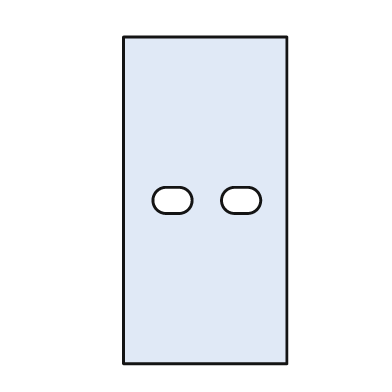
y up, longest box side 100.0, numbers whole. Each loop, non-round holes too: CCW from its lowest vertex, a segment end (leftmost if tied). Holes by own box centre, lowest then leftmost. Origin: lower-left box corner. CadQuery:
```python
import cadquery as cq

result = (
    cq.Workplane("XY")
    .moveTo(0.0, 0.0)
    .lineTo(50.0, 0.0)
    .lineTo(50.0, 100.0)
    .lineTo(0.0, 100.0)
    .close()
    .moveTo(13.0, 46.0)
    .lineTo(17.0, 46.0)
    .threePointArc((21.0, 50.0), (17.0, 54.0))
    .lineTo(13.0, 54.0)
    .threePointArc((9.0, 50.0), (13.0, 46.0))
    .close()
    .moveTo(34.0, 46.0)
    .lineTo(38.0, 46.0)
    .threePointArc((42.0, 50.0), (38.0, 54.0))
    .lineTo(34.0, 54.0)
    .threePointArc((30.0, 50.0), (34.0, 46.0))
    .close()
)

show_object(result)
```